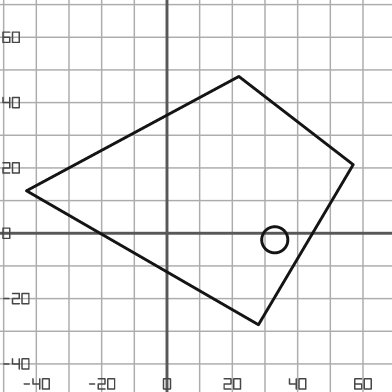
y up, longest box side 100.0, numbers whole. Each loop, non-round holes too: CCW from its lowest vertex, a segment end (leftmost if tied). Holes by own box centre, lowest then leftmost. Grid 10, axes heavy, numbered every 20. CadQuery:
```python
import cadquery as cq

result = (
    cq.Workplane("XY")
    .moveTo(28.0, -28.0)
    .lineTo(57.0, 21.0)
    .lineTo(22.0, 48.0)
    .lineTo(-43.0, 13.0)
    .close()
    .moveTo(33.0, -2.0)
    .circle(4.0)
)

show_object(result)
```